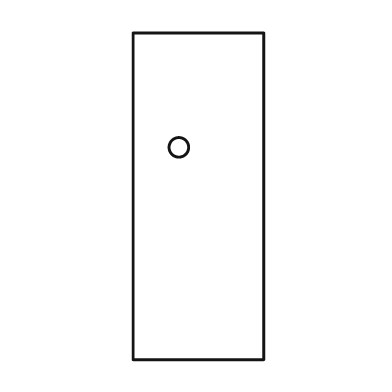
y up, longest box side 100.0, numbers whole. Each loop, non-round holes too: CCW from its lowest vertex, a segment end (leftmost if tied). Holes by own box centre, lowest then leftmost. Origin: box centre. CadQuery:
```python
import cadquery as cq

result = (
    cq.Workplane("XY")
    .moveTo(-20.0, -50.0)
    .lineTo(20.0, -50.0)
    .lineTo(20.0, 50.0)
    .lineTo(-20.0, 50.0)
    .close()
    .moveTo(-6.0, 15.0)
    .circle(3.0)
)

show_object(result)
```